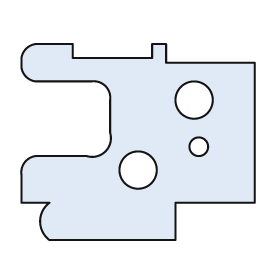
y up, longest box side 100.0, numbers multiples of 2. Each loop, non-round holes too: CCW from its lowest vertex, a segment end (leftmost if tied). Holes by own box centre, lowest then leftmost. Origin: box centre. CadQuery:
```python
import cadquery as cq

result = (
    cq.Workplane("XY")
    .moveTo(-38.0, -42.0)
    .lineTo(16.0, -42.0)
    .lineTo(16.0, -26.0)
    .lineTo(50.0, -26.0)
    .lineTo(50.0, 34.0)
    .lineTo(12.0, 34.0)
    .lineTo(12.0, 42.0)
    .lineTo(6.0, 42.0)
    .lineTo(6.0, 36.0)
    .lineTo(-28.0, 36.0)
    .lineTo(-28.0, 42.0)
    .lineTo(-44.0, 42.0)
    .threePointArc((-48.0, 40.0), (-50.0, 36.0))
    .lineTo(-50.0, 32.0)
    .threePointArc((-48.0, 28.0), (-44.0, 26.0))
    .lineTo(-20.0, 26.0)
    .threePointArc((-14.0, 24.0), (-12.0, 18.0))
    .lineTo(-12.0, 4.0)
    .threePointArc((-14.0, -4.0), (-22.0, -6.0))
    .lineTo(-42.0, -6.0)
    .threePointArc((-48.0, -8.0), (-50.0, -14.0))
    .lineTo(-50.0, -26.0)
    .lineTo(-38.0, -26.0)
    .threePointArc((-42.0, -34.0), (-38.0, -42.0))
    .close()
    .moveTo(0.0, -12.0)
    .circle(8.0)
    .moveTo(26.0, -2.0)
    .circle(4.0)
    .moveTo(24.0, 18.0)
    .circle(8.0)
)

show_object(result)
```